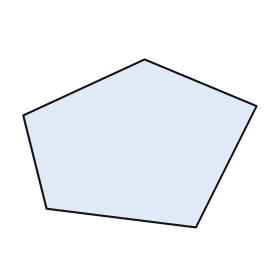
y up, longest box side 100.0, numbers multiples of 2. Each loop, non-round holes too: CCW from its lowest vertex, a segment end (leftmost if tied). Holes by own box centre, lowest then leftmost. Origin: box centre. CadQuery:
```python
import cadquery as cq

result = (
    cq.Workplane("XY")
    .moveTo(24.0, -36.0)
    .lineTo(50.0, 16.0)
    .lineTo(2.0, 36.0)
    .lineTo(-50.0, 12.0)
    .lineTo(-40.0, -28.0)
    .close()
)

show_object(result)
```